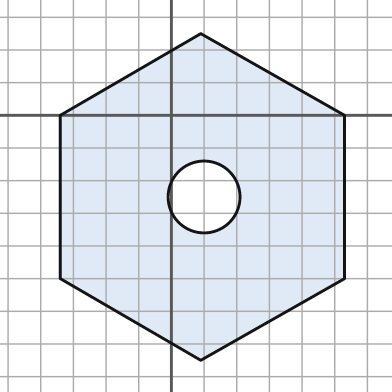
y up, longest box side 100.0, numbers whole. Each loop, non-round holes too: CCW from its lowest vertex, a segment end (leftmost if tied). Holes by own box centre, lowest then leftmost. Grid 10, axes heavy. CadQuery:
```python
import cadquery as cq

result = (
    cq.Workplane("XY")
    .moveTo(9.0, -75.0)
    .lineTo(53.0, -50.0)
    .lineTo(53.0, 0.0)
    .lineTo(9.0, 25.0)
    .lineTo(-34.0, 0.0)
    .lineTo(-34.0, -50.0)
    .close()
    .moveTo(10.0, -25.0)
    .circle(11.0)
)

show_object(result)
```